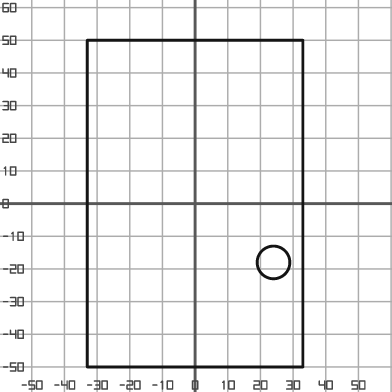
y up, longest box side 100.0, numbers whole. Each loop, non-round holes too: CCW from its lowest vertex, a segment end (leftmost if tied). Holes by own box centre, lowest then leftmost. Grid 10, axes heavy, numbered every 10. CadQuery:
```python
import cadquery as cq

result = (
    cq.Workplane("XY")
    .moveTo(-33.0, -50.0)
    .lineTo(33.0, -50.0)
    .lineTo(33.0, 50.0)
    .lineTo(-33.0, 50.0)
    .close()
    .moveTo(24.0, -18.0)
    .circle(5.0)
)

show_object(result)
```